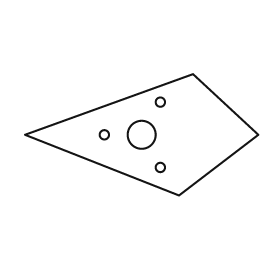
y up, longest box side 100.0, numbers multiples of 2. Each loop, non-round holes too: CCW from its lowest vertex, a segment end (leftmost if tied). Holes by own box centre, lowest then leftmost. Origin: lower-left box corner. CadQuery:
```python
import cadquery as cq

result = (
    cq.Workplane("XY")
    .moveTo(66.0, 0.0)
    .lineTo(100.0, 26.0)
    .lineTo(72.0, 52.0)
    .lineTo(0.0, 26.0)
    .close()
    .moveTo(58.0, 12.0)
    .circle(2.0)
    .moveTo(34.0, 26.0)
    .circle(2.0)
    .moveTo(50.0, 26.0)
    .circle(6.0)
    .moveTo(58.0, 40.0)
    .circle(2.0)
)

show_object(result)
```